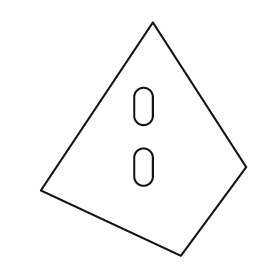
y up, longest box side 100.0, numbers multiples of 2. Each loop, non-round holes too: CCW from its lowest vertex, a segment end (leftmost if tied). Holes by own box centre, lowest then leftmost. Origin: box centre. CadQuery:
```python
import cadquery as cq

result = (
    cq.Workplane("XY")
    .moveTo(16.0, -50.0)
    .lineTo(44.0, -12.0)
    .lineTo(4.0, 50.0)
    .lineTo(-44.0, -22.0)
    .close()
    .moveTo(-4.0, -16.0)
    .threePointArc((0.0, -20.0), (4.0, -16.0))
    .lineTo(4.0, -8.0)
    .threePointArc((0.0, -4.0), (-4.0, -8.0))
    .close()
    .moveTo(-4.0, 10.0)
    .threePointArc((0.0, 6.0), (4.0, 10.0))
    .lineTo(4.0, 18.0)
    .threePointArc((0.0, 22.0), (-4.0, 18.0))
    .close()
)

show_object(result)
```